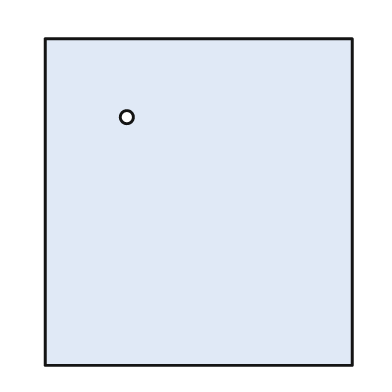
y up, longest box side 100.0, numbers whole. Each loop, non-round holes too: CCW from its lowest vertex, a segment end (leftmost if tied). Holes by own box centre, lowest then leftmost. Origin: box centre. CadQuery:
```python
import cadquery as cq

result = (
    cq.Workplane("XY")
    .moveTo(-47.0, -50.0)
    .lineTo(47.0, -50.0)
    .lineTo(47.0, 50.0)
    .lineTo(-47.0, 50.0)
    .close()
    .moveTo(-22.0, 26.0)
    .circle(2.0)
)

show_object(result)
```